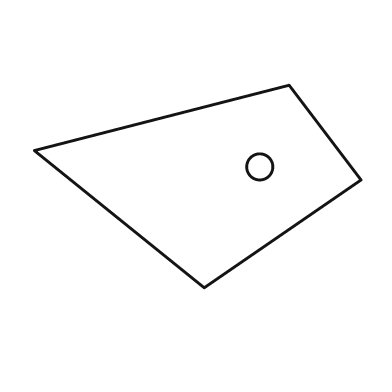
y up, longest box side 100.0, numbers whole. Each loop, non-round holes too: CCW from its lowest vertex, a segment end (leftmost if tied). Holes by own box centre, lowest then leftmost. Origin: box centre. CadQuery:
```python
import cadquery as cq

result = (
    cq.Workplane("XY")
    .moveTo(2.0, -31.0)
    .lineTo(50.0, 2.0)
    .lineTo(28.0, 31.0)
    .lineTo(-50.0, 11.0)
    .close()
    .moveTo(19.0, 6.0)
    .circle(4.0)
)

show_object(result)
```